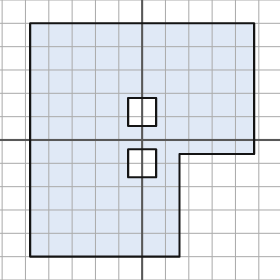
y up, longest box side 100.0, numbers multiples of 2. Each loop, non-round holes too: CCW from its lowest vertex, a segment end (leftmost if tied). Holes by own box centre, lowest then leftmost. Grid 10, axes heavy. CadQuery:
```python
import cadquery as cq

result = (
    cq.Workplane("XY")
    .moveTo(-48.0, -50.0)
    .lineTo(16.0, -50.0)
    .lineTo(16.0, -6.0)
    .lineTo(48.0, -6.0)
    .lineTo(48.0, 50.0)
    .lineTo(-48.0, 50.0)
    .close()
    .moveTo(-6.0, -16.0)
    .lineTo(6.0, -16.0)
    .lineTo(6.0, -4.0)
    .lineTo(-6.0, -4.0)
    .close()
    .moveTo(-6.0, 6.0)
    .lineTo(6.0, 6.0)
    .lineTo(6.0, 18.0)
    .lineTo(-6.0, 18.0)
    .close()
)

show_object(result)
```